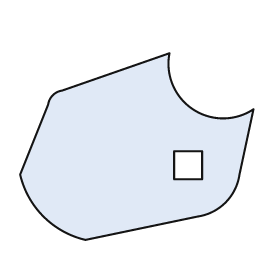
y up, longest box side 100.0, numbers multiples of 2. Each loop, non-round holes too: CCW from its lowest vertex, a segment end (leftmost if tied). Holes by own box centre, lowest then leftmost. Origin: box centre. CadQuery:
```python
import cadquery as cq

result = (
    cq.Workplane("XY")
    .moveTo(-22.0, -40.0)
    .lineTo(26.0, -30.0)
    .threePointArc((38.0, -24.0), (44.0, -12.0))
    .lineTo(50.0, 16.0)
    .threePointArc((24.0, 16.0), (14.0, 40.0))
    .lineTo(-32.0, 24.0)
    .threePointArc((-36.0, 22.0), (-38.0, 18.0))
    .lineTo(-50.0, -12.0)
    .threePointArc((-40.0, -30.0), (-22.0, -40.0))
    .close()
    .moveTo(16.0, -14.0)
    .lineTo(28.0, -14.0)
    .lineTo(28.0, -2.0)
    .lineTo(16.0, -2.0)
    .close()
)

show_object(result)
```